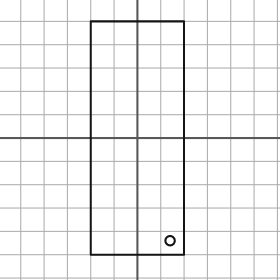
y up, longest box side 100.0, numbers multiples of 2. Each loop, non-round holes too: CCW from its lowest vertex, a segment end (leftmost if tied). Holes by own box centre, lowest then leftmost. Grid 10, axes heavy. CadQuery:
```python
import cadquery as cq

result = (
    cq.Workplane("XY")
    .moveTo(-20.0, -50.0)
    .lineTo(20.0, -50.0)
    .lineTo(20.0, 50.0)
    .lineTo(-20.0, 50.0)
    .close()
    .moveTo(14.0, -44.0)
    .circle(2.0)
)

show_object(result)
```